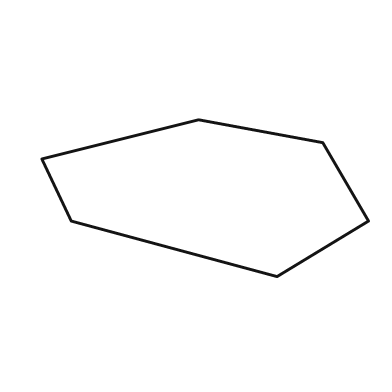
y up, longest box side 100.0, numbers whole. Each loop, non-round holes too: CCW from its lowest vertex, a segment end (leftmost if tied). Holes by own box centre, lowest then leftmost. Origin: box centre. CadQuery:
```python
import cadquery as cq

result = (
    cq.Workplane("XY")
    .moveTo(22.0, -24.0)
    .lineTo(50.0, -7.0)
    .lineTo(36.0, 17.0)
    .lineTo(-2.0, 24.0)
    .lineTo(-50.0, 12.0)
    .lineTo(-41.0, -7.0)
    .close()
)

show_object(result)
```